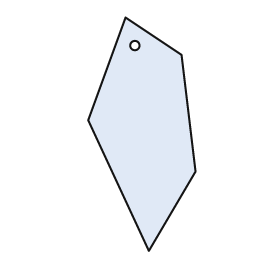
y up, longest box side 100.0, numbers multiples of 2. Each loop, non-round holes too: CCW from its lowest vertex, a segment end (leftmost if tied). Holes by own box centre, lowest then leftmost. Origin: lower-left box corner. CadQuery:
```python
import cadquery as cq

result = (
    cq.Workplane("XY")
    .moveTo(26.0, 0.0)
    .lineTo(46.0, 34.0)
    .lineTo(40.0, 84.0)
    .lineTo(16.0, 100.0)
    .lineTo(0.0, 56.0)
    .close()
    .moveTo(20.0, 88.0)
    .circle(2.0)
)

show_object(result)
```